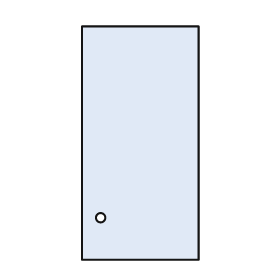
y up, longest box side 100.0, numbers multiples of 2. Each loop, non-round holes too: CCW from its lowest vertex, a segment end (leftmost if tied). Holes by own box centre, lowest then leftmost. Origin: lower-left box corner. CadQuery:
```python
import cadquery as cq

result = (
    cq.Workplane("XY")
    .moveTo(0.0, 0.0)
    .lineTo(50.0, 0.0)
    .lineTo(50.0, 100.0)
    .lineTo(0.0, 100.0)
    .close()
    .moveTo(8.0, 18.0)
    .circle(2.0)
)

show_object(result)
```